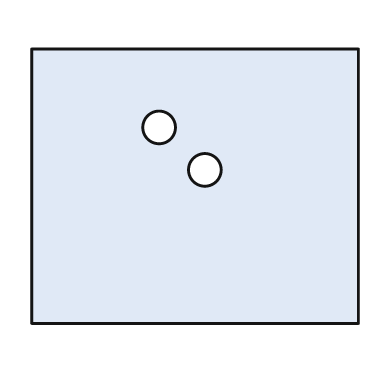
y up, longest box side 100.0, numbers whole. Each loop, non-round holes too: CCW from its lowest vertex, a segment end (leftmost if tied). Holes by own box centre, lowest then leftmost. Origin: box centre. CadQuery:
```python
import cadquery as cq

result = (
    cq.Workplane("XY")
    .moveTo(-50.0, -42.0)
    .lineTo(50.0, -42.0)
    .lineTo(50.0, 42.0)
    .lineTo(-50.0, 42.0)
    .close()
    .moveTo(3.0, 5.0)
    .circle(5.0)
    .moveTo(-11.0, 18.0)
    .circle(5.0)
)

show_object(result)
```